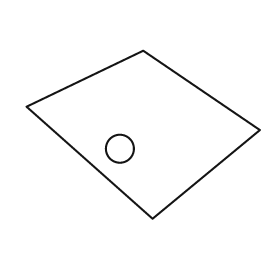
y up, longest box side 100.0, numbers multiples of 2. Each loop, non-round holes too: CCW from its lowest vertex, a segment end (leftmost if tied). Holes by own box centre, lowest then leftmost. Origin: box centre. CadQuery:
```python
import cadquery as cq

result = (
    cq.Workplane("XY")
    .moveTo(4.0, -36.0)
    .lineTo(50.0, 2.0)
    .lineTo(0.0, 36.0)
    .lineTo(-50.0, 12.0)
    .close()
    .moveTo(-10.0, -6.0)
    .circle(6.0)
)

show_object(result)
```